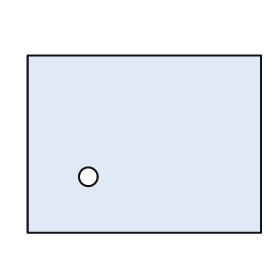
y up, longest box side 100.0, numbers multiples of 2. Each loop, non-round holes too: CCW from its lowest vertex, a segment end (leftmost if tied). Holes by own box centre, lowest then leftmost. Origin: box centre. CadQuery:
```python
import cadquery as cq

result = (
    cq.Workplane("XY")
    .moveTo(-50.0, -38.0)
    .lineTo(50.0, -38.0)
    .lineTo(50.0, 38.0)
    .lineTo(-50.0, 38.0)
    .close()
    .moveTo(-24.0, -14.0)
    .circle(4.0)
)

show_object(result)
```